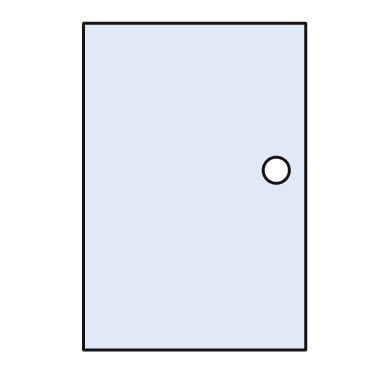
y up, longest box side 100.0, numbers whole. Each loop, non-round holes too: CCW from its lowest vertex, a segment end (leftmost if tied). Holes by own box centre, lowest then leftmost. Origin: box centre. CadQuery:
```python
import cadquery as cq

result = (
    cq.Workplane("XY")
    .moveTo(-34.0, -50.0)
    .lineTo(34.0, -50.0)
    .lineTo(34.0, 50.0)
    .lineTo(-34.0, 50.0)
    .close()
    .moveTo(25.0, 5.0)
    .circle(4.0)
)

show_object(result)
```